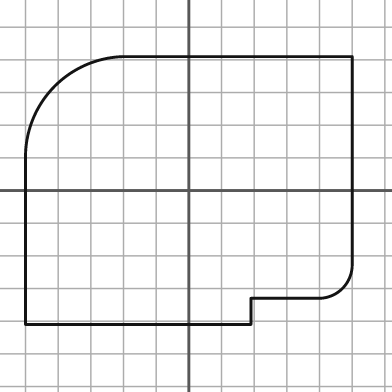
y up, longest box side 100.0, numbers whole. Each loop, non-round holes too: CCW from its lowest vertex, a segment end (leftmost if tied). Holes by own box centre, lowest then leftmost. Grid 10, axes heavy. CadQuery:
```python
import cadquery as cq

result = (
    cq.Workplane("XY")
    .moveTo(-50.0, -41.0)
    .lineTo(19.0, -41.0)
    .lineTo(19.0, -33.0)
    .lineTo(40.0, -33.0)
    .threePointArc((47.0, -30.0), (50.0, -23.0))
    .lineTo(50.0, 41.0)
    .lineTo(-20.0, 41.0)
    .threePointArc((-41.0, 32.0), (-50.0, 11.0))
    .close()
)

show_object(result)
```